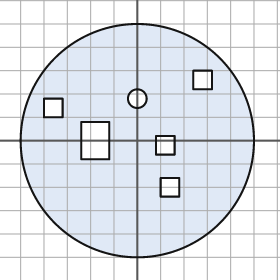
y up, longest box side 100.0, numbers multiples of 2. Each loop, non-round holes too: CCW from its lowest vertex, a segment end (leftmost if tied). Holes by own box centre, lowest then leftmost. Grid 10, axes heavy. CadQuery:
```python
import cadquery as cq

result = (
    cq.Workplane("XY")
    .moveTo(0.0, 0.0)
    .circle(50.0)
    .moveTo(10.0, -24.0)
    .lineTo(18.0, -24.0)
    .lineTo(18.0, -16.0)
    .lineTo(10.0, -16.0)
    .close()
    .moveTo(8.0, -6.0)
    .lineTo(16.0, -6.0)
    .lineTo(16.0, 2.0)
    .lineTo(8.0, 2.0)
    .close()
    .moveTo(-24.0, -8.0)
    .lineTo(-12.0, -8.0)
    .lineTo(-12.0, 8.0)
    .lineTo(-24.0, 8.0)
    .close()
    .moveTo(-40.0, 10.0)
    .lineTo(-32.0, 10.0)
    .lineTo(-32.0, 18.0)
    .lineTo(-40.0, 18.0)
    .close()
    .moveTo(0.0, 18.0)
    .circle(4.0)
    .moveTo(24.0, 22.0)
    .lineTo(32.0, 22.0)
    .lineTo(32.0, 30.0)
    .lineTo(24.0, 30.0)
    .close()
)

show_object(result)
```